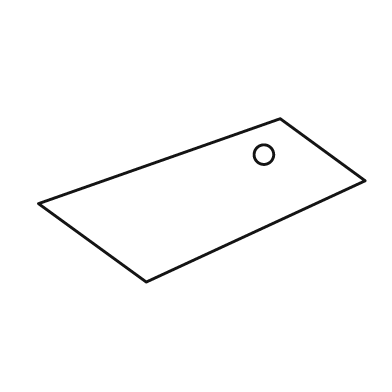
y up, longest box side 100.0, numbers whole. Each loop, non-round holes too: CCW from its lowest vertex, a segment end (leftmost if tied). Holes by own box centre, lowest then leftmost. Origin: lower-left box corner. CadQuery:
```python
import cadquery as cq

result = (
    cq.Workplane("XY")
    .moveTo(33.0, 0.0)
    .lineTo(100.0, 31.0)
    .lineTo(74.0, 50.0)
    .lineTo(0.0, 24.0)
    .close()
    .moveTo(69.0, 39.0)
    .circle(3.0)
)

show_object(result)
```